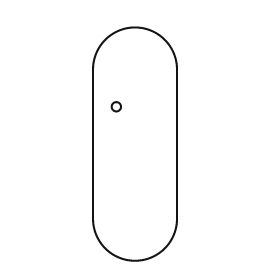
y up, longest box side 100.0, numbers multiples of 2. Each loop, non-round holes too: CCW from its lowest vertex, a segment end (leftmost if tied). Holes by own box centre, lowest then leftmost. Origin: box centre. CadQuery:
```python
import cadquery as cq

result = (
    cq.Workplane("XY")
    .moveTo(-18.0, -32.0)
    .threePointArc((0.0, -50.0), (18.0, -32.0))
    .lineTo(18.0, 32.0)
    .threePointArc((0.0, 50.0), (-18.0, 32.0))
    .close()
    .moveTo(-8.0, 16.0)
    .circle(2.0)
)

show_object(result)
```